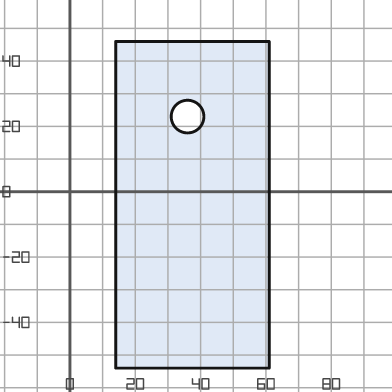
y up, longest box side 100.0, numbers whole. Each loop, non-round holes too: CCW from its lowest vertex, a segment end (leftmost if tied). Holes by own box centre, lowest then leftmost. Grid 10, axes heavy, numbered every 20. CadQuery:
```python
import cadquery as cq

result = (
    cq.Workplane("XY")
    .moveTo(14.0, -54.0)
    .lineTo(61.0, -54.0)
    .lineTo(61.0, 46.0)
    .lineTo(14.0, 46.0)
    .close()
    .moveTo(36.0, 23.0)
    .circle(5.0)
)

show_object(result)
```